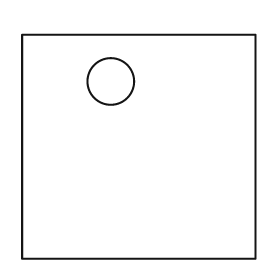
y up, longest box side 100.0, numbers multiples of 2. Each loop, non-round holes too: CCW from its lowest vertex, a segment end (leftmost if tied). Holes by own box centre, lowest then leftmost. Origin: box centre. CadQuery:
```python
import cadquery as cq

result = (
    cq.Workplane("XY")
    .moveTo(-50.0, -48.0)
    .lineTo(50.0, -48.0)
    .lineTo(50.0, 48.0)
    .lineTo(-50.0, 48.0)
    .close()
    .moveTo(-12.0, 28.0)
    .circle(10.0)
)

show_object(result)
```